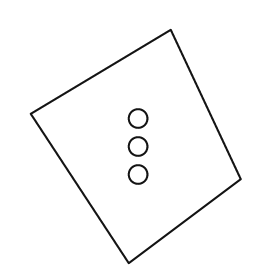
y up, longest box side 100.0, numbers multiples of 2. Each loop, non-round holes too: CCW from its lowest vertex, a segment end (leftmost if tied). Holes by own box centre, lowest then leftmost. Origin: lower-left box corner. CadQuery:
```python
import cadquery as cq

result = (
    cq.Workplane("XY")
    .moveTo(42.0, 0.0)
    .lineTo(90.0, 36.0)
    .lineTo(60.0, 100.0)
    .lineTo(0.0, 64.0)
    .close()
    .moveTo(46.0, 38.0)
    .circle(4.0)
    .moveTo(46.0, 50.0)
    .circle(4.0)
    .moveTo(46.0, 62.0)
    .circle(4.0)
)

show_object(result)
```